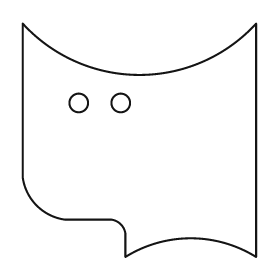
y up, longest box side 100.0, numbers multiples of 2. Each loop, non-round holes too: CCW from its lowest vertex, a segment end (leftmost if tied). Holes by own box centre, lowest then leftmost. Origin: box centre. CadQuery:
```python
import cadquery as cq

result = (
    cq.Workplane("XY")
    .moveTo(-6.0, -50.0)
    .threePointArc((22.0, -42.0), (50.0, -50.0))
    .lineTo(50.0, 50.0)
    .threePointArc((0.0, 28.0), (-50.0, 50.0))
    .lineTo(-50.0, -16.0)
    .threePointArc((-44.0, -28.0), (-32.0, -34.0))
    .lineTo(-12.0, -34.0)
    .threePointArc((-8.0, -36.0), (-6.0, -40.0))
    .close()
    .moveTo(-26.0, 16.0)
    .circle(4.0)
    .moveTo(-8.0, 16.0)
    .circle(4.0)
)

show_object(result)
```